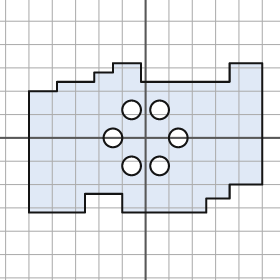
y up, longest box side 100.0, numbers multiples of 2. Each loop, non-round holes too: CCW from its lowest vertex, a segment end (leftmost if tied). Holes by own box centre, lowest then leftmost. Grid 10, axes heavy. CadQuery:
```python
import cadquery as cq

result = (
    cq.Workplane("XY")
    .moveTo(-50.0, -32.0)
    .lineTo(-26.0, -32.0)
    .lineTo(-26.0, -24.0)
    .lineTo(-10.0, -24.0)
    .lineTo(-10.0, -32.0)
    .lineTo(26.0, -32.0)
    .lineTo(26.0, -26.0)
    .lineTo(36.0, -26.0)
    .lineTo(36.0, -20.0)
    .lineTo(50.0, -20.0)
    .lineTo(50.0, 32.0)
    .lineTo(36.0, 32.0)
    .lineTo(36.0, 24.0)
    .lineTo(-2.0, 24.0)
    .lineTo(-2.0, 32.0)
    .lineTo(-14.0, 32.0)
    .lineTo(-14.0, 28.0)
    .lineTo(-22.0, 28.0)
    .lineTo(-22.0, 24.0)
    .lineTo(-38.0, 24.0)
    .lineTo(-38.0, 20.0)
    .lineTo(-50.0, 20.0)
    .close()
    .moveTo(-6.0, -12.0)
    .circle(4.0)
    .moveTo(6.0, -12.0)
    .circle(4.0)
    .moveTo(-14.0, 0.0)
    .circle(4.0)
    .moveTo(14.0, 0.0)
    .circle(4.0)
    .moveTo(-6.0, 12.0)
    .circle(4.0)
    .moveTo(6.0, 12.0)
    .circle(4.0)
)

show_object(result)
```